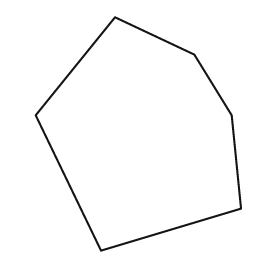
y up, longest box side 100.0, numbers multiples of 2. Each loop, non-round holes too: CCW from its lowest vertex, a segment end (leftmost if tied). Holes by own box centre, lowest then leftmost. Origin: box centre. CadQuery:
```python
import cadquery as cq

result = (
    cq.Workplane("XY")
    .moveTo(-16.0, -50.0)
    .lineTo(44.0, -32.0)
    .lineTo(40.0, 8.0)
    .lineTo(24.0, 34.0)
    .lineTo(-10.0, 50.0)
    .lineTo(-44.0, 8.0)
    .close()
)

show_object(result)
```